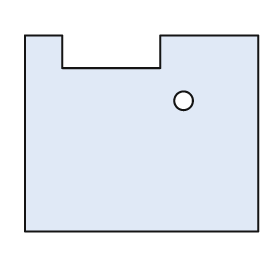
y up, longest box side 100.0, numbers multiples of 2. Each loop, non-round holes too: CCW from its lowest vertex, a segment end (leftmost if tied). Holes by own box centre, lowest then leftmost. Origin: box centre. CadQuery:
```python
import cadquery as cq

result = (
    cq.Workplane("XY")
    .moveTo(-50.0, -42.0)
    .lineTo(50.0, -42.0)
    .lineTo(50.0, 42.0)
    .lineTo(8.0, 42.0)
    .lineTo(8.0, 28.0)
    .lineTo(-34.0, 28.0)
    .lineTo(-34.0, 42.0)
    .lineTo(-50.0, 42.0)
    .close()
    .moveTo(18.0, 14.0)
    .circle(4.0)
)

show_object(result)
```